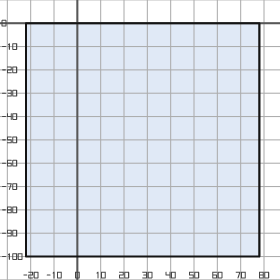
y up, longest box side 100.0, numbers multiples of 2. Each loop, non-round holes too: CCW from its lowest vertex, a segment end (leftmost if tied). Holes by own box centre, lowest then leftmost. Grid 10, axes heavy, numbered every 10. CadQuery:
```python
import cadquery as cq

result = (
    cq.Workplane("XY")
    .moveTo(-22.0, -100.0)
    .lineTo(78.0, -100.0)
    .lineTo(78.0, 0.0)
    .lineTo(-22.0, 0.0)
    .close()
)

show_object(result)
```